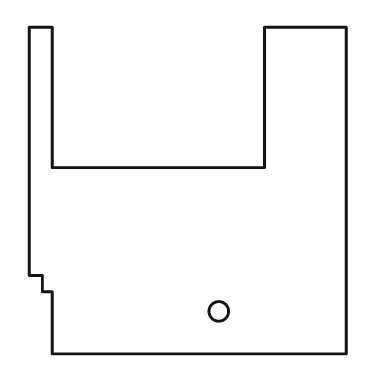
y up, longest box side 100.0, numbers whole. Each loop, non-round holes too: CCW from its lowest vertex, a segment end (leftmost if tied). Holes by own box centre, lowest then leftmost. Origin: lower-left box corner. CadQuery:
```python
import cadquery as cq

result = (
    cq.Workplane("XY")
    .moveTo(7.0, 0.0)
    .lineTo(97.0, 0.0)
    .lineTo(97.0, 100.0)
    .lineTo(72.0, 100.0)
    .lineTo(72.0, 57.0)
    .lineTo(7.0, 57.0)
    .lineTo(7.0, 100.0)
    .lineTo(0.0, 100.0)
    .lineTo(0.0, 24.0)
    .lineTo(4.0, 24.0)
    .lineTo(4.0, 19.0)
    .lineTo(7.0, 19.0)
    .close()
    .moveTo(58.0, 13.0)
    .circle(3.0)
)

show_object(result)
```